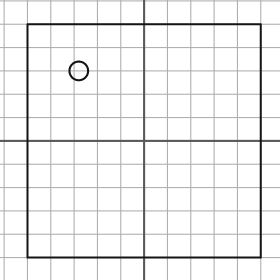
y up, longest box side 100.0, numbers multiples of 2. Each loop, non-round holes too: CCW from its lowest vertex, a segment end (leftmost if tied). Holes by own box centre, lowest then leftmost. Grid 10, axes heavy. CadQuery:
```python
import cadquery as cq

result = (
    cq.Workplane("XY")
    .moveTo(-50.0, -50.0)
    .lineTo(50.0, -50.0)
    .lineTo(50.0, 50.0)
    .lineTo(-50.0, 50.0)
    .close()
    .moveTo(-28.0, 30.0)
    .circle(4.0)
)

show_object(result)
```